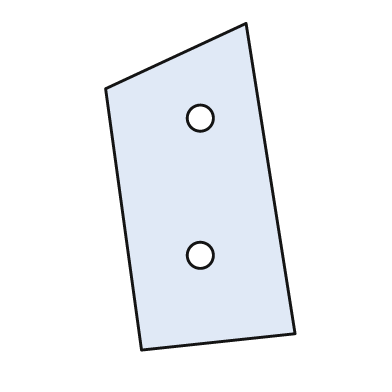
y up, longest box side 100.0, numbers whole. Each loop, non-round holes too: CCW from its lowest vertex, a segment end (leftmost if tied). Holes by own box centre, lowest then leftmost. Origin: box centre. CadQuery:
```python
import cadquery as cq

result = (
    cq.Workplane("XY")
    .moveTo(-18.0, -50.0)
    .lineTo(29.0, -45.0)
    .lineTo(14.0, 50.0)
    .lineTo(-29.0, 30.0)
    .close()
    .moveTo(0.0, -21.0)
    .circle(4.0)
    .moveTo(0.0, 21.0)
    .circle(4.0)
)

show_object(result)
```